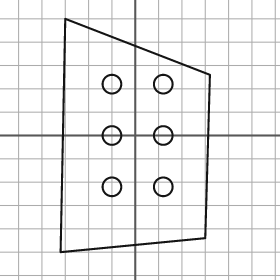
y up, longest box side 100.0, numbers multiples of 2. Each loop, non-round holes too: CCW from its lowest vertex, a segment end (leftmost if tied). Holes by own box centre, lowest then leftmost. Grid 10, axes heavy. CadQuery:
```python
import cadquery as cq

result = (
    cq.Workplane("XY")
    .moveTo(-32.0, -50.0)
    .lineTo(30.0, -44.0)
    .lineTo(32.0, 26.0)
    .lineTo(-30.0, 50.0)
    .close()
    .moveTo(-10.0, -22.0)
    .circle(4.0)
    .moveTo(12.0, -22.0)
    .circle(4.0)
    .moveTo(-10.0, 0.0)
    .circle(4.0)
    .moveTo(12.0, 0.0)
    .circle(4.0)
    .moveTo(-10.0, 22.0)
    .circle(4.0)
    .moveTo(12.0, 22.0)
    .circle(4.0)
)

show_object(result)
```